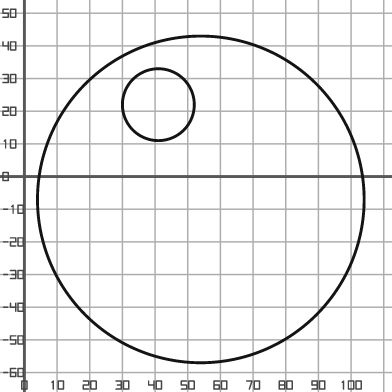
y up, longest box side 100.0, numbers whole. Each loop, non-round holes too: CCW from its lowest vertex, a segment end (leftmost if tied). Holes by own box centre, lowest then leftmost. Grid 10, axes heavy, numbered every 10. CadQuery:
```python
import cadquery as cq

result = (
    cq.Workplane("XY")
    .moveTo(54.0, -7.0)
    .circle(50.0)
    .moveTo(41.0, 22.0)
    .circle(11.0)
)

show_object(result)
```